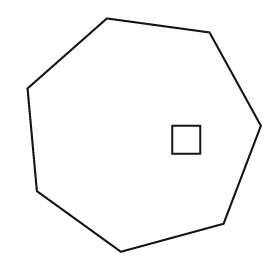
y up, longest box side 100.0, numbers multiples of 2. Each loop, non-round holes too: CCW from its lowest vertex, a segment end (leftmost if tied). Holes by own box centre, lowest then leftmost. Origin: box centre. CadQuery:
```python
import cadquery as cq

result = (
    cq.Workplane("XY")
    .moveTo(-10.0, -50.0)
    .lineTo(34.0, -38.0)
    .lineTo(50.0, 4.0)
    .lineTo(28.0, 44.0)
    .lineTo(-16.0, 50.0)
    .lineTo(-50.0, 20.0)
    .lineTo(-46.0, -24.0)
    .close()
    .moveTo(12.0, -8.0)
    .lineTo(24.0, -8.0)
    .lineTo(24.0, 4.0)
    .lineTo(12.0, 4.0)
    .close()
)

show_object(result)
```